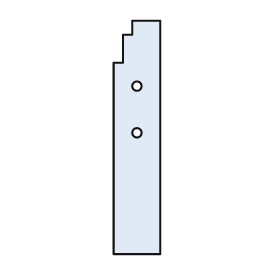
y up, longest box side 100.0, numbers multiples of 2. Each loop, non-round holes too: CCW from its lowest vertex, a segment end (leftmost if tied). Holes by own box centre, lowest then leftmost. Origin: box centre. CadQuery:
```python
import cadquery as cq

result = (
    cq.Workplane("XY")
    .moveTo(-10.0, -50.0)
    .lineTo(10.0, -50.0)
    .lineTo(10.0, 50.0)
    .lineTo(-2.0, 50.0)
    .lineTo(-2.0, 44.0)
    .lineTo(-6.0, 44.0)
    .lineTo(-6.0, 32.0)
    .lineTo(-10.0, 32.0)
    .close()
    .moveTo(0.0, 2.0)
    .circle(2.0)
    .moveTo(0.0, 22.0)
    .circle(2.0)
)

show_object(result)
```